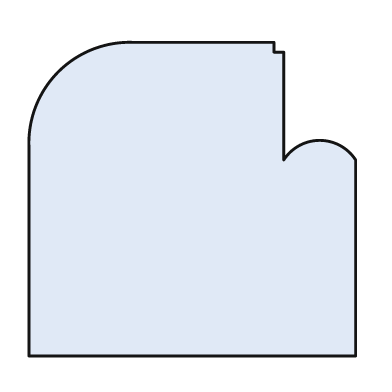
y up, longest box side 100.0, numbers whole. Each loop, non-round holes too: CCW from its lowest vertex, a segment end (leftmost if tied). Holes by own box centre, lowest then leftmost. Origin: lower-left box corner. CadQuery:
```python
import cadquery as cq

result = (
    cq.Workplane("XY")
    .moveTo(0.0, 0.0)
    .lineTo(100.0, 0.0)
    .lineTo(100.0, 60.0)
    .threePointArc((89.0, 66.0), (78.0, 60.0))
    .lineTo(78.0, 93.0)
    .lineTo(75.0, 93.0)
    .lineTo(75.0, 96.0)
    .lineTo(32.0, 96.0)
    .threePointArc((9.0, 87.0), (0.0, 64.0))
    .close()
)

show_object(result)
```